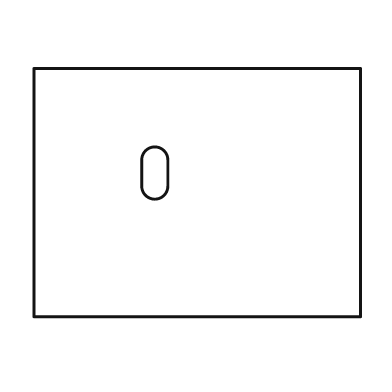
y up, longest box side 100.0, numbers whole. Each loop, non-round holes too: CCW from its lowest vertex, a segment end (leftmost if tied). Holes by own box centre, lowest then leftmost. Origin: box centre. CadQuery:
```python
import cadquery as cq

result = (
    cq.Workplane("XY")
    .moveTo(-50.0, -38.0)
    .lineTo(50.0, -38.0)
    .lineTo(50.0, 38.0)
    .lineTo(-50.0, 38.0)
    .close()
    .moveTo(-17.0, 2.0)
    .threePointArc((-13.0, -2.0), (-9.0, 2.0))
    .lineTo(-9.0, 10.0)
    .threePointArc((-13.0, 14.0), (-17.0, 10.0))
    .close()
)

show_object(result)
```